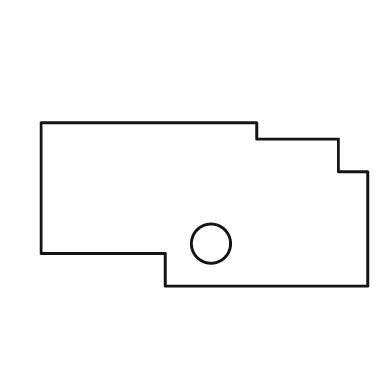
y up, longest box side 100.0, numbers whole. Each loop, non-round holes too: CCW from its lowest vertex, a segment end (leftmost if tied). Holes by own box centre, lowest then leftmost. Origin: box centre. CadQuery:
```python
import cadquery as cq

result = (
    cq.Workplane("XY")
    .moveTo(-12.0, -25.0)
    .lineTo(50.0, -25.0)
    .lineTo(50.0, 10.0)
    .lineTo(41.0, 10.0)
    .lineTo(41.0, 20.0)
    .lineTo(16.0, 20.0)
    .lineTo(16.0, 25.0)
    .lineTo(-50.0, 25.0)
    .lineTo(-50.0, -15.0)
    .lineTo(-12.0, -15.0)
    .close()
    .moveTo(2.0, -12.0)
    .circle(6.0)
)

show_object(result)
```